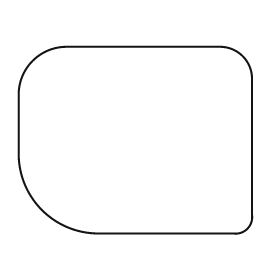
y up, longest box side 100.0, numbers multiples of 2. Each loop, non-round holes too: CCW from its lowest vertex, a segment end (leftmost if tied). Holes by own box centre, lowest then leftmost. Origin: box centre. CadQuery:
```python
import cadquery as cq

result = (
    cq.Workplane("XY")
    .moveTo(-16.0, -40.0)
    .lineTo(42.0, -40.0)
    .threePointArc((48.0, -38.0), (50.0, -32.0))
    .lineTo(50.0, 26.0)
    .threePointArc((46.0, 36.0), (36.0, 40.0))
    .lineTo(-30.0, 40.0)
    .threePointArc((-44.0, 34.0), (-50.0, 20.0))
    .lineTo(-50.0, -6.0)
    .threePointArc((-40.0, -30.0), (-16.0, -40.0))
    .close()
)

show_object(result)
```